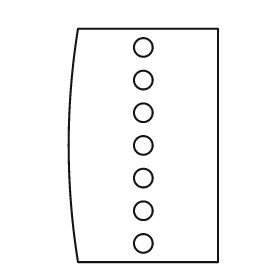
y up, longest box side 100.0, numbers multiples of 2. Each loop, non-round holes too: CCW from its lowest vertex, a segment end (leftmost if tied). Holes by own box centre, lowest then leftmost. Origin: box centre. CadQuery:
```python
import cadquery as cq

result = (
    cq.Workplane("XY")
    .moveTo(-28.0, -50.0)
    .lineTo(32.0, -50.0)
    .lineTo(32.0, 50.0)
    .lineTo(-28.0, 50.0)
    .threePointArc((-32.0, 0.0), (-28.0, -50.0))
    .close()
    .moveTo(0.0, -42.0)
    .circle(4.0)
    .moveTo(0.0, -28.0)
    .circle(4.0)
    .moveTo(0.0, -14.0)
    .circle(4.0)
    .moveTo(0.0, 0.0)
    .circle(4.0)
    .moveTo(0.0, 14.0)
    .circle(4.0)
    .moveTo(0.0, 28.0)
    .circle(4.0)
    .moveTo(0.0, 42.0)
    .circle(4.0)
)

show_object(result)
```